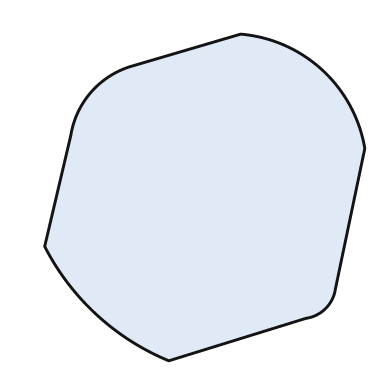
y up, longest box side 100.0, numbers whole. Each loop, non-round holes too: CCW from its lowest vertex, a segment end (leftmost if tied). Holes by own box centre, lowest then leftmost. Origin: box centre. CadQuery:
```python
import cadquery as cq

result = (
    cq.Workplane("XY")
    .moveTo(-11.0, -50.0)
    .lineTo(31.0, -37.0)
    .threePointArc((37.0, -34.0), (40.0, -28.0))
    .lineTo(49.0, 15.0)
    .threePointArc((36.0, 39.0), (11.0, 50.0))
    .lineTo(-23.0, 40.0)
    .threePointArc((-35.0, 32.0), (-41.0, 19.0))
    .lineTo(-49.0, -15.0)
    .threePointArc((-33.0, -36.0), (-11.0, -50.0))
    .close()
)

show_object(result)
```